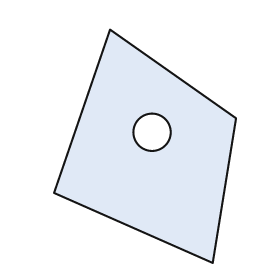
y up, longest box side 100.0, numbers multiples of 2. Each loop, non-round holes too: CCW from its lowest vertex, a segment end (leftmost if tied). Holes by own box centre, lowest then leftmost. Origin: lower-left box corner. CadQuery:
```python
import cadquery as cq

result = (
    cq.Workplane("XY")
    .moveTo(68.0, 0.0)
    .lineTo(78.0, 62.0)
    .lineTo(24.0, 100.0)
    .lineTo(0.0, 30.0)
    .close()
    .moveTo(42.0, 56.0)
    .circle(8.0)
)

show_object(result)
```